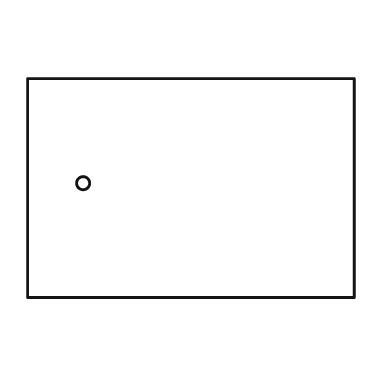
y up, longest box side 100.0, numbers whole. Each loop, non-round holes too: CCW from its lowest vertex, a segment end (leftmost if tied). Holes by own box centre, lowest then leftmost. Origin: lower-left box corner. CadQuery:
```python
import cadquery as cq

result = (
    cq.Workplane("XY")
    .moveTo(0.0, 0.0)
    .lineTo(100.0, 0.0)
    .lineTo(100.0, 67.0)
    .lineTo(0.0, 67.0)
    .close()
    .moveTo(17.0, 35.0)
    .circle(2.0)
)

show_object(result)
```